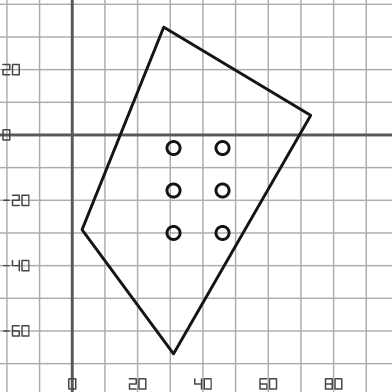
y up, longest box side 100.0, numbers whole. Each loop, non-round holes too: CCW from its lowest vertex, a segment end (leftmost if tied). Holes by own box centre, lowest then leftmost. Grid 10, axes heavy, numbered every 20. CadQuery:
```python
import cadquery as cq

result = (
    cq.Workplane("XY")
    .moveTo(31.0, -67.0)
    .lineTo(73.0, 6.0)
    .lineTo(28.0, 33.0)
    .lineTo(3.0, -29.0)
    .close()
    .moveTo(31.0, -30.0)
    .circle(2.0)
    .moveTo(46.0, -30.0)
    .circle(2.0)
    .moveTo(31.0, -17.0)
    .circle(2.0)
    .moveTo(46.0, -17.0)
    .circle(2.0)
    .moveTo(31.0, -4.0)
    .circle(2.0)
    .moveTo(46.0, -4.0)
    .circle(2.0)
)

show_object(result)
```